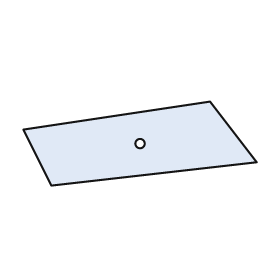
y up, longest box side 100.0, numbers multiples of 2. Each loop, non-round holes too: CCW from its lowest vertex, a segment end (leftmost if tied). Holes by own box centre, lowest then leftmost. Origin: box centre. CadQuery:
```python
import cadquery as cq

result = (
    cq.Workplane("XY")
    .moveTo(-38.0, -18.0)
    .lineTo(50.0, -8.0)
    .lineTo(30.0, 18.0)
    .lineTo(-50.0, 6.0)
    .close()
    .moveTo(0.0, 0.0)
    .circle(2.0)
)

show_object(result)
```